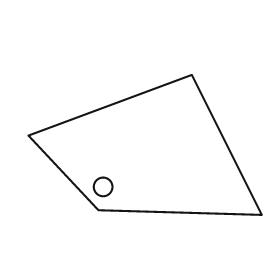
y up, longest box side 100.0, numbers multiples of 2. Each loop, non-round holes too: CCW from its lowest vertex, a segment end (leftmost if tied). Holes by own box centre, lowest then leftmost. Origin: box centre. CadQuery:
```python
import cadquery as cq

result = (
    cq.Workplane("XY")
    .moveTo(50.0, -30.0)
    .lineTo(20.0, 30.0)
    .lineTo(-50.0, 4.0)
    .lineTo(-20.0, -28.0)
    .close()
    .moveTo(-18.0, -18.0)
    .circle(4.0)
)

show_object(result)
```